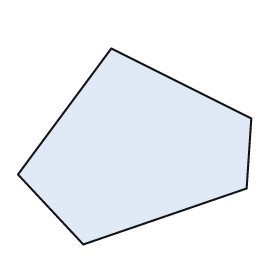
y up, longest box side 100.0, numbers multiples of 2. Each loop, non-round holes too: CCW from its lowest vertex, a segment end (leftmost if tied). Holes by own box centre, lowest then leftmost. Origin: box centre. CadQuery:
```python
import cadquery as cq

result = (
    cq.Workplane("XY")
    .moveTo(-22.0, -42.0)
    .lineTo(48.0, -18.0)
    .lineTo(50.0, 12.0)
    .lineTo(-10.0, 42.0)
    .lineTo(-50.0, -12.0)
    .close()
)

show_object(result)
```